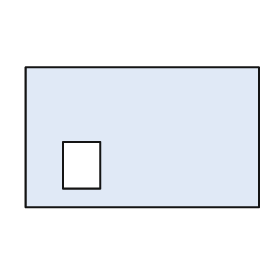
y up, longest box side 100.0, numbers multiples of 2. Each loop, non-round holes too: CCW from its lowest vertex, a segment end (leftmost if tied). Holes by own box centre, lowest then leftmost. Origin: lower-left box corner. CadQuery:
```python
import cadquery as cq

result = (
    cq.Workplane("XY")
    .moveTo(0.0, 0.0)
    .lineTo(100.0, 0.0)
    .lineTo(100.0, 60.0)
    .lineTo(0.0, 60.0)
    .close()
    .moveTo(16.0, 8.0)
    .lineTo(32.0, 8.0)
    .lineTo(32.0, 28.0)
    .lineTo(16.0, 28.0)
    .close()
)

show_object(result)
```